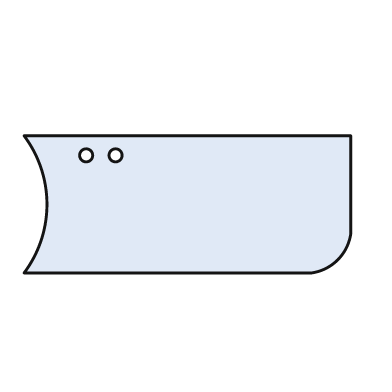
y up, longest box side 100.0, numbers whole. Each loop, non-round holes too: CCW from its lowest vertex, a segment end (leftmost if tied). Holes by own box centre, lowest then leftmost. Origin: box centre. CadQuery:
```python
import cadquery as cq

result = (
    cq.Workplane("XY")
    .moveTo(-50.0, -21.0)
    .lineTo(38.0, -21.0)
    .threePointArc((46.0, -17.0), (50.0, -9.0))
    .lineTo(50.0, 21.0)
    .lineTo(-50.0, 21.0)
    .threePointArc((-43.0, 0.0), (-50.0, -21.0))
    .close()
    .moveTo(-31.0, 15.0)
    .circle(2.0)
    .moveTo(-22.0, 15.0)
    .circle(2.0)
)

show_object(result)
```